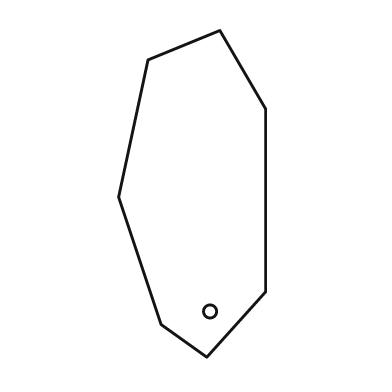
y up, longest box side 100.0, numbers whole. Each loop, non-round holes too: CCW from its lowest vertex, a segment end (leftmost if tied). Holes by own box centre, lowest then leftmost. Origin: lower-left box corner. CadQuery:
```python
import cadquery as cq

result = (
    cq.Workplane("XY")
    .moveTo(27.0, 0.0)
    .lineTo(45.0, 20.0)
    .lineTo(45.0, 76.0)
    .lineTo(31.0, 100.0)
    .lineTo(9.0, 91.0)
    .lineTo(0.0, 49.0)
    .lineTo(13.0, 10.0)
    .close()
    .moveTo(28.0, 14.0)
    .circle(2.0)
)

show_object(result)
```